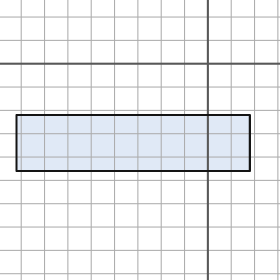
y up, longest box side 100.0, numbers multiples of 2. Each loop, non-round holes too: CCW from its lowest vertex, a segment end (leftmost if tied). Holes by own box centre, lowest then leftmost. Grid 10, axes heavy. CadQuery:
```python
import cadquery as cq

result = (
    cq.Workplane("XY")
    .moveTo(-82.0, -46.0)
    .lineTo(18.0, -46.0)
    .lineTo(18.0, -22.0)
    .lineTo(-82.0, -22.0)
    .close()
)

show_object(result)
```